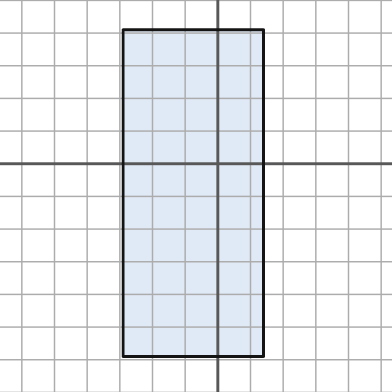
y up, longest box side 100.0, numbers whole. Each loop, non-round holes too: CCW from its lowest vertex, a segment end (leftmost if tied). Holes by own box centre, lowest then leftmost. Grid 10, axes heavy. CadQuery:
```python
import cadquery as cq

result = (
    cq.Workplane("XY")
    .moveTo(-29.0, -59.0)
    .lineTo(14.0, -59.0)
    .lineTo(14.0, 41.0)
    .lineTo(-29.0, 41.0)
    .close()
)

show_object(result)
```